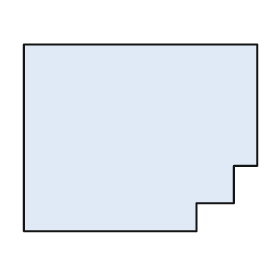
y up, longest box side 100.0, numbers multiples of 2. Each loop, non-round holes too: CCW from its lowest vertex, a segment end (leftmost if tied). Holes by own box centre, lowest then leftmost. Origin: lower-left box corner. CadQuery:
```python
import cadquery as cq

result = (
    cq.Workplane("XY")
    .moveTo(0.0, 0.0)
    .lineTo(74.0, 0.0)
    .lineTo(74.0, 12.0)
    .lineTo(90.0, 12.0)
    .lineTo(90.0, 28.0)
    .lineTo(100.0, 28.0)
    .lineTo(100.0, 80.0)
    .lineTo(0.0, 80.0)
    .close()
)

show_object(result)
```